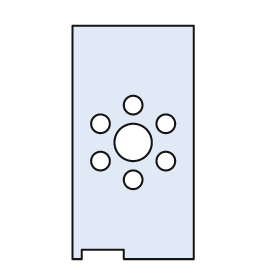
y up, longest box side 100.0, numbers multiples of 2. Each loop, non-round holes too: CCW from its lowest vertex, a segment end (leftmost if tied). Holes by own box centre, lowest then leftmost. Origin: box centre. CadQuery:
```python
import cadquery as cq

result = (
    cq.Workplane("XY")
    .moveTo(-26.0, -50.0)
    .lineTo(-22.0, -50.0)
    .lineTo(-22.0, -46.0)
    .lineTo(-4.0, -46.0)
    .lineTo(-4.0, -50.0)
    .lineTo(26.0, -50.0)
    .lineTo(26.0, 50.0)
    .lineTo(-26.0, 50.0)
    .close()
    .moveTo(0.0, -16.0)
    .circle(4.0)
    .moveTo(-14.0, -8.0)
    .circle(4.0)
    .moveTo(14.0, -8.0)
    .circle(4.0)
    .moveTo(0.0, 0.0)
    .circle(8.0)
    .moveTo(-14.0, 8.0)
    .circle(4.0)
    .moveTo(14.0, 8.0)
    .circle(4.0)
    .moveTo(0.0, 16.0)
    .circle(4.0)
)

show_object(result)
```